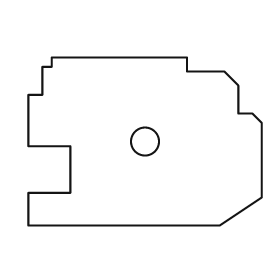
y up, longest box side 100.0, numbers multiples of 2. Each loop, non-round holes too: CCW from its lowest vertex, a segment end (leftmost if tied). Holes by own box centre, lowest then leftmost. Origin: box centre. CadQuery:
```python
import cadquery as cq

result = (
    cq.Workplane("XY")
    .moveTo(-50.0, -36.0)
    .lineTo(32.0, -36.0)
    .lineTo(50.0, -24.0)
    .lineTo(50.0, 8.0)
    .lineTo(46.0, 12.0)
    .lineTo(40.0, 12.0)
    .lineTo(40.0, 24.0)
    .lineTo(34.0, 30.0)
    .lineTo(18.0, 30.0)
    .lineTo(18.0, 36.0)
    .lineTo(-40.0, 36.0)
    .lineTo(-40.0, 32.0)
    .lineTo(-44.0, 32.0)
    .lineTo(-44.0, 20.0)
    .lineTo(-50.0, 20.0)
    .lineTo(-50.0, -2.0)
    .lineTo(-32.0, -2.0)
    .lineTo(-32.0, -22.0)
    .lineTo(-50.0, -22.0)
    .close()
    .moveTo(0.0, 0.0)
    .circle(6.0)
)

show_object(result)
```